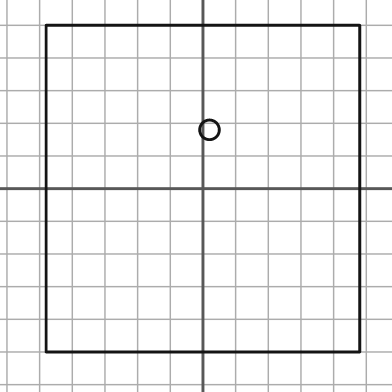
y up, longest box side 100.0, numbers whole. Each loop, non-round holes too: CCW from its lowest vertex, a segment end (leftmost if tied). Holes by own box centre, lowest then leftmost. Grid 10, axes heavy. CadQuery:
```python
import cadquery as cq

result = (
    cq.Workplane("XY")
    .moveTo(-48.0, -50.0)
    .lineTo(48.0, -50.0)
    .lineTo(48.0, 50.0)
    .lineTo(-48.0, 50.0)
    .close()
    .moveTo(2.0, 18.0)
    .circle(3.0)
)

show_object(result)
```